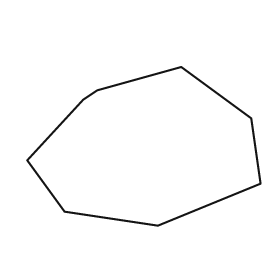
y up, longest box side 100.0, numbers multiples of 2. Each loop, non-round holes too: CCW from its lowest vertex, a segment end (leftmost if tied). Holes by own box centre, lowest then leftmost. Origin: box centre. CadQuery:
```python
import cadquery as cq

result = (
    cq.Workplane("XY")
    .moveTo(6.0, -34.0)
    .lineTo(50.0, -16.0)
    .lineTo(46.0, 12.0)
    .lineTo(16.0, 34.0)
    .lineTo(-20.0, 24.0)
    .lineTo(-26.0, 20.0)
    .lineTo(-50.0, -6.0)
    .lineTo(-34.0, -28.0)
    .close()
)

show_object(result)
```